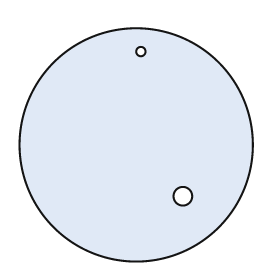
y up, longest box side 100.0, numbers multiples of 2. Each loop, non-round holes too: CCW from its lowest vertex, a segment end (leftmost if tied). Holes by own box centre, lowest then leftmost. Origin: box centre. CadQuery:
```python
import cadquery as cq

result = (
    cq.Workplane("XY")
    .moveTo(0.0, 0.0)
    .circle(50.0)
    .moveTo(20.0, -22.0)
    .circle(4.0)
    .moveTo(2.0, 40.0)
    .circle(2.0)
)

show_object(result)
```